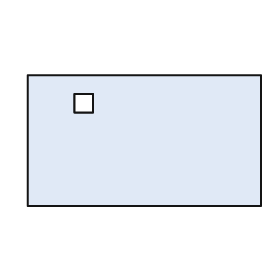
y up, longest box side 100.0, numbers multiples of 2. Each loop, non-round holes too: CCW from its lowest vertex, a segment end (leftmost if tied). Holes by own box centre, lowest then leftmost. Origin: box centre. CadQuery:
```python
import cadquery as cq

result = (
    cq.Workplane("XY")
    .moveTo(-50.0, -28.0)
    .lineTo(50.0, -28.0)
    .lineTo(50.0, 28.0)
    .lineTo(-50.0, 28.0)
    .close()
    .moveTo(-30.0, 12.0)
    .lineTo(-22.0, 12.0)
    .lineTo(-22.0, 20.0)
    .lineTo(-30.0, 20.0)
    .close()
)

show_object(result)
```